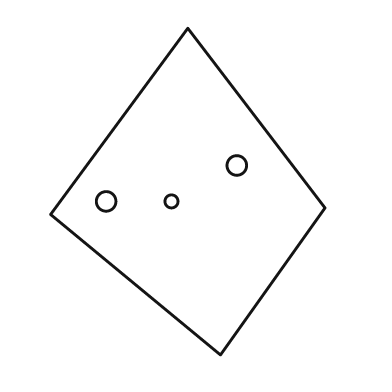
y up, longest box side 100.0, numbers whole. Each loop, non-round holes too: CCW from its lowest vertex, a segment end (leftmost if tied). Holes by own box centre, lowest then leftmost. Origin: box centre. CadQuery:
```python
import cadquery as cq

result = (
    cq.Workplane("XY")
    .moveTo(10.0, -50.0)
    .lineTo(42.0, -5.0)
    .lineTo(0.0, 50.0)
    .lineTo(-42.0, -7.0)
    .close()
    .moveTo(-25.0, -3.0)
    .circle(3.0)
    .moveTo(-5.0, -3.0)
    .circle(2.0)
    .moveTo(15.0, 8.0)
    .circle(3.0)
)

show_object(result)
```